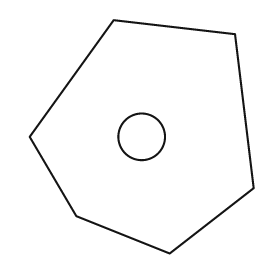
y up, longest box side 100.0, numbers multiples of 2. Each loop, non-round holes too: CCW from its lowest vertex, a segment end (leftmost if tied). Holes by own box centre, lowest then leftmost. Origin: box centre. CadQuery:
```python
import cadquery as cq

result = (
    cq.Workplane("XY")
    .moveTo(12.0, -50.0)
    .lineTo(48.0, -22.0)
    .lineTo(40.0, 44.0)
    .lineTo(-12.0, 50.0)
    .lineTo(-48.0, 0.0)
    .lineTo(-28.0, -34.0)
    .close()
    .moveTo(0.0, 0.0)
    .circle(10.0)
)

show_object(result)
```